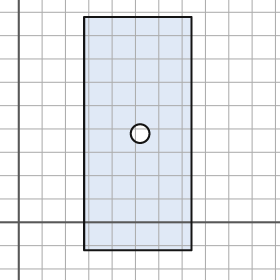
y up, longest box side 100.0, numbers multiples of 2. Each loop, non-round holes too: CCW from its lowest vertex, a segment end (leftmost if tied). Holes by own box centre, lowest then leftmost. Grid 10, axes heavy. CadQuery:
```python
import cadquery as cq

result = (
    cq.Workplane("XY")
    .moveTo(28.0, -12.0)
    .lineTo(74.0, -12.0)
    .lineTo(74.0, 88.0)
    .lineTo(28.0, 88.0)
    .close()
    .moveTo(52.0, 38.0)
    .circle(4.0)
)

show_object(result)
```